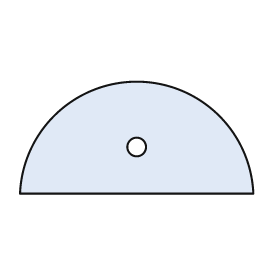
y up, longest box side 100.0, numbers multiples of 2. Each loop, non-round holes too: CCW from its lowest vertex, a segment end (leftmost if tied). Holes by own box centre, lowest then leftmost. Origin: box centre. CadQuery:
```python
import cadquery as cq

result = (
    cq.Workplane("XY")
    .moveTo(-50.0, -24.0)
    .lineTo(50.0, -24.0)
    .threePointArc((0.0, 24.0), (-50.0, -24.0))
    .close()
    .moveTo(0.0, -4.0)
    .circle(4.0)
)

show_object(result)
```